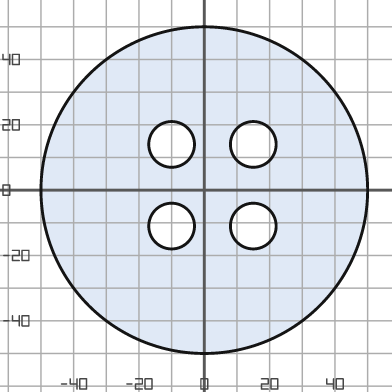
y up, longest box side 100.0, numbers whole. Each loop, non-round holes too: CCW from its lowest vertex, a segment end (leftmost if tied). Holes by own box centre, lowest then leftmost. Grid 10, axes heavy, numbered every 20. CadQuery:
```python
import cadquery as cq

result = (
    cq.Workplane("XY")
    .moveTo(0.0, 0.0)
    .circle(50.0)
    .moveTo(-10.0, -11.0)
    .circle(7.0)
    .moveTo(15.0, -11.0)
    .circle(7.0)
    .moveTo(-10.0, 14.0)
    .circle(7.0)
    .moveTo(15.0, 14.0)
    .circle(7.0)
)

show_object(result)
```